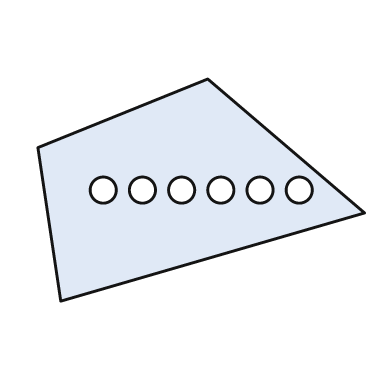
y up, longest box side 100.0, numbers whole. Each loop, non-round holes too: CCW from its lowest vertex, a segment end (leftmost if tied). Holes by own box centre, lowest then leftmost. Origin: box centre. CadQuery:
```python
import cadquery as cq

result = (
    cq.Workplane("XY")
    .moveTo(-43.0, -34.0)
    .lineTo(50.0, -7.0)
    .lineTo(2.0, 34.0)
    .lineTo(-50.0, 13.0)
    .close()
    .moveTo(-30.0, 0.0)
    .circle(4.0)
    .moveTo(-18.0, 0.0)
    .circle(4.0)
    .moveTo(-6.0, 0.0)
    .circle(4.0)
    .moveTo(6.0, 0.0)
    .circle(4.0)
    .moveTo(18.0, 0.0)
    .circle(4.0)
    .moveTo(30.0, 0.0)
    .circle(4.0)
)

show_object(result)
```